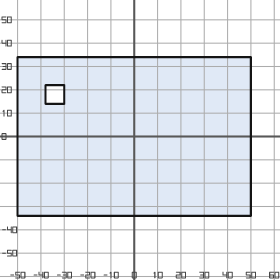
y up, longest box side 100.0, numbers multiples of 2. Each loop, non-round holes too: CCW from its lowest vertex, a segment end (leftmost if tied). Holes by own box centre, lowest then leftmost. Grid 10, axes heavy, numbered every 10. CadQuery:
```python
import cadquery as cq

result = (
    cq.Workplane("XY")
    .moveTo(-50.0, -34.0)
    .lineTo(50.0, -34.0)
    .lineTo(50.0, 34.0)
    .lineTo(-50.0, 34.0)
    .close()
    .moveTo(-38.0, 14.0)
    .lineTo(-30.0, 14.0)
    .lineTo(-30.0, 22.0)
    .lineTo(-38.0, 22.0)
    .close()
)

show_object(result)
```